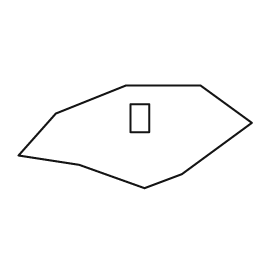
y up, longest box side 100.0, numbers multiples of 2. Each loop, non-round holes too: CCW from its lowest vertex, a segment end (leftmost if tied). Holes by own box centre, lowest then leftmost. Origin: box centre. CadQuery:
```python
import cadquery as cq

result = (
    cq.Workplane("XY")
    .moveTo(4.0, -22.0)
    .lineTo(20.0, -16.0)
    .lineTo(50.0, 6.0)
    .lineTo(28.0, 22.0)
    .lineTo(-4.0, 22.0)
    .lineTo(-34.0, 10.0)
    .lineTo(-50.0, -8.0)
    .lineTo(-24.0, -12.0)
    .close()
    .moveTo(-2.0, 2.0)
    .lineTo(6.0, 2.0)
    .lineTo(6.0, 14.0)
    .lineTo(-2.0, 14.0)
    .close()
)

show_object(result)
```